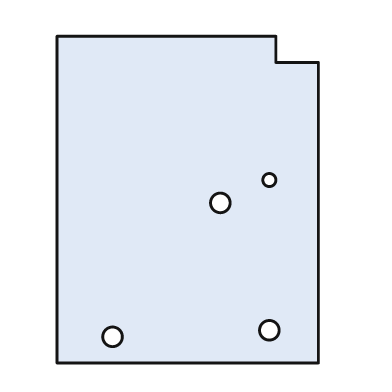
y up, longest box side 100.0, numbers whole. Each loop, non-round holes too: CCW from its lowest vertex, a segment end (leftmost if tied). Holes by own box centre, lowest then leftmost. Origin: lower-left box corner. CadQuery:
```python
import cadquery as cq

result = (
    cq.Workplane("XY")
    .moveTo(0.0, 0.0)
    .lineTo(80.0, 0.0)
    .lineTo(80.0, 92.0)
    .lineTo(67.0, 92.0)
    .lineTo(67.0, 100.0)
    .lineTo(0.0, 100.0)
    .close()
    .moveTo(17.0, 8.0)
    .circle(3.0)
    .moveTo(65.0, 10.0)
    .circle(3.0)
    .moveTo(50.0, 49.0)
    .circle(3.0)
    .moveTo(65.0, 56.0)
    .circle(2.0)
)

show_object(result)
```